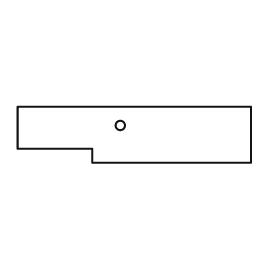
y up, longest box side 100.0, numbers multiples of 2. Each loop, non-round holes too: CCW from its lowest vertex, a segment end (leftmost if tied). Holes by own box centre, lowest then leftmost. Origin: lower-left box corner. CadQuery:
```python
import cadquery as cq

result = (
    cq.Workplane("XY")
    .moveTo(32.0, 0.0)
    .lineTo(100.0, 0.0)
    .lineTo(100.0, 24.0)
    .lineTo(0.0, 24.0)
    .lineTo(0.0, 6.0)
    .lineTo(32.0, 6.0)
    .close()
    .moveTo(44.0, 16.0)
    .circle(2.0)
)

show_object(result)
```